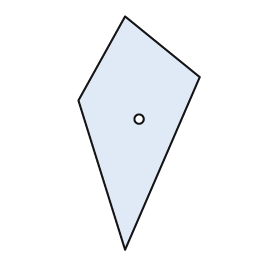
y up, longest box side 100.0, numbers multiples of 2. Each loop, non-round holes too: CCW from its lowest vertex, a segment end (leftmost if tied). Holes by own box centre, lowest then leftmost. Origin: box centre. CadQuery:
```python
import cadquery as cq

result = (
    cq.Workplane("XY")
    .moveTo(-6.0, -50.0)
    .lineTo(26.0, 24.0)
    .lineTo(-6.0, 50.0)
    .lineTo(-26.0, 14.0)
    .close()
    .moveTo(0.0, 6.0)
    .circle(2.0)
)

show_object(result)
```